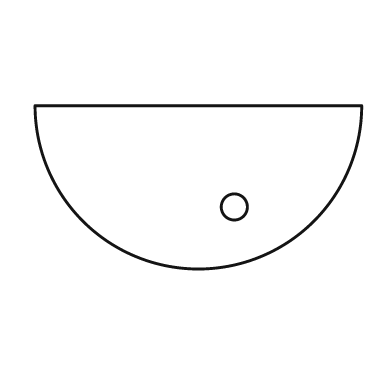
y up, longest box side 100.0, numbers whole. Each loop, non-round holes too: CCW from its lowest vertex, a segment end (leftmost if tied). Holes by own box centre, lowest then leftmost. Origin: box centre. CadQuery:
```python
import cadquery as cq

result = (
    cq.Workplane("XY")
    .moveTo(-50.0, 25.0)
    .threePointArc((0.0, -25.0), (50.0, 25.0))
    .close()
    .moveTo(11.0, -6.0)
    .circle(4.0)
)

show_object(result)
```